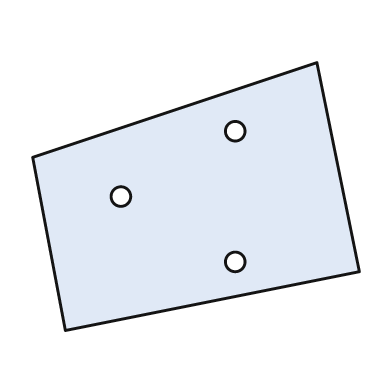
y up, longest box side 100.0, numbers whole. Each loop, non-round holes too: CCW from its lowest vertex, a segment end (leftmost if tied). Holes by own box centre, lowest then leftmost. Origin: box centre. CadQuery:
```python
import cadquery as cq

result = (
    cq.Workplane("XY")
    .moveTo(-40.0, -41.0)
    .lineTo(50.0, -23.0)
    .lineTo(37.0, 41.0)
    .lineTo(-50.0, 12.0)
    .close()
    .moveTo(12.0, -20.0)
    .circle(3.0)
    .moveTo(-23.0, 0.0)
    .circle(3.0)
    .moveTo(12.0, 20.0)
    .circle(3.0)
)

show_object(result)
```